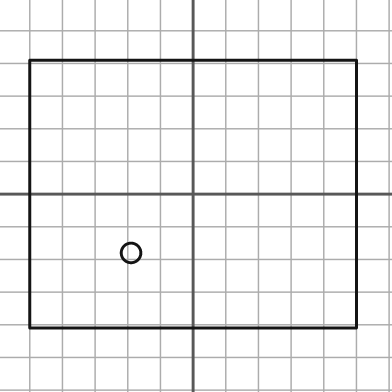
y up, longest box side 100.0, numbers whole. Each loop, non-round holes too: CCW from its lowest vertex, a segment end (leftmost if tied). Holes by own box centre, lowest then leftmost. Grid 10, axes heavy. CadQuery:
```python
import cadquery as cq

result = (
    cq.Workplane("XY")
    .moveTo(-50.0, -41.0)
    .lineTo(50.0, -41.0)
    .lineTo(50.0, 41.0)
    .lineTo(-50.0, 41.0)
    .close()
    .moveTo(-19.0, -18.0)
    .circle(3.0)
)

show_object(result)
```